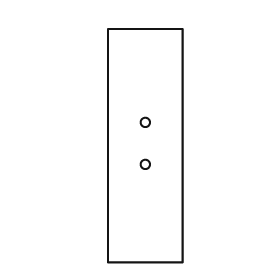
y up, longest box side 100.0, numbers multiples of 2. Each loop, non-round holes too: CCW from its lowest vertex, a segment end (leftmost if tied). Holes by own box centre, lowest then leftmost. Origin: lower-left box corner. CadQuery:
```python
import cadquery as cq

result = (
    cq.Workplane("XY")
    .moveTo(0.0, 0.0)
    .lineTo(32.0, 0.0)
    .lineTo(32.0, 100.0)
    .lineTo(0.0, 100.0)
    .close()
    .moveTo(16.0, 42.0)
    .circle(2.0)
    .moveTo(16.0, 60.0)
    .circle(2.0)
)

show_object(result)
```